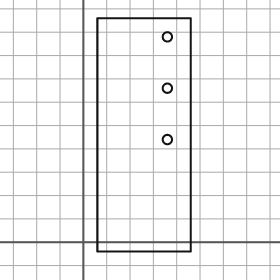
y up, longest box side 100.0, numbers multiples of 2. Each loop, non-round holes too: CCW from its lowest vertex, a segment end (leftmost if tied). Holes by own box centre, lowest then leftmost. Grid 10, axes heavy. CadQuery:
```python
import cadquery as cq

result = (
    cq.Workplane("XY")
    .moveTo(6.0, -4.0)
    .lineTo(46.0, -4.0)
    .lineTo(46.0, 96.0)
    .lineTo(6.0, 96.0)
    .close()
    .moveTo(36.0, 44.0)
    .circle(2.0)
    .moveTo(36.0, 66.0)
    .circle(2.0)
    .moveTo(36.0, 88.0)
    .circle(2.0)
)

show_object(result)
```